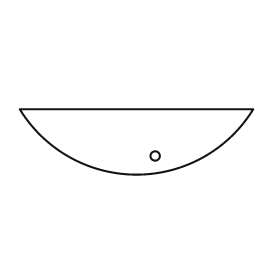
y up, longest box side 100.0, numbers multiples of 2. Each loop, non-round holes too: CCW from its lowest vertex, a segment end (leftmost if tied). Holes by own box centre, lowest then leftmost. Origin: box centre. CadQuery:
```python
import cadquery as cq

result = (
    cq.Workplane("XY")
    .moveTo(-50.0, 14.0)
    .threePointArc((0.0, -14.0), (50.0, 14.0))
    .close()
    .moveTo(8.0, -6.0)
    .circle(2.0)
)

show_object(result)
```